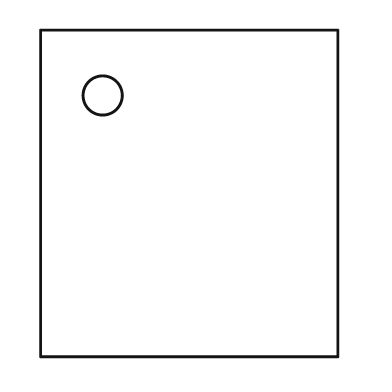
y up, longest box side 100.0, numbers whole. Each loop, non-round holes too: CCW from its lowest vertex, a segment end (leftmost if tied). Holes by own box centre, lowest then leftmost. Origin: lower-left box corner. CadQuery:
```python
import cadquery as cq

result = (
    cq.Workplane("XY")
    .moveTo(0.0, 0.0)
    .lineTo(91.0, 0.0)
    .lineTo(91.0, 100.0)
    .lineTo(0.0, 100.0)
    .close()
    .moveTo(19.0, 80.0)
    .circle(6.0)
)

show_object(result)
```